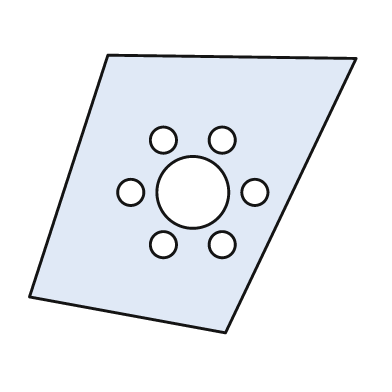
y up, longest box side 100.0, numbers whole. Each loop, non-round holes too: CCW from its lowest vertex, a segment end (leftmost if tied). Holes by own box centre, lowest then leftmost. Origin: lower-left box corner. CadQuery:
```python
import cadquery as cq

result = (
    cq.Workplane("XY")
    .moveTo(60.0, 0.0)
    .lineTo(100.0, 84.0)
    .lineTo(24.0, 85.0)
    .lineTo(0.0, 11.0)
    .close()
    .moveTo(41.0, 27.0)
    .circle(4.0)
    .moveTo(59.0, 27.0)
    .circle(4.0)
    .moveTo(31.0, 43.0)
    .circle(4.0)
    .moveTo(50.0, 43.0)
    .circle(11.0)
    .moveTo(69.0, 43.0)
    .circle(4.0)
    .moveTo(41.0, 59.0)
    .circle(4.0)
    .moveTo(59.0, 59.0)
    .circle(4.0)
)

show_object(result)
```